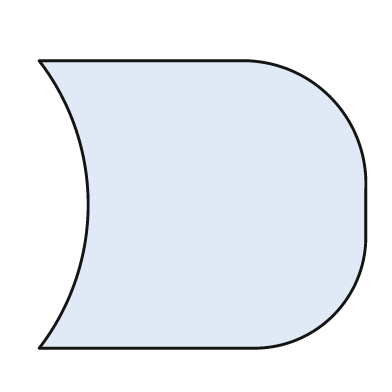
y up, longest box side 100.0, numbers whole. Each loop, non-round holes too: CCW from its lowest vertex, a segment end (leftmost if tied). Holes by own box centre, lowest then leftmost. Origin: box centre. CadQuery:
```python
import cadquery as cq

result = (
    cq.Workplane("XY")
    .moveTo(-50.0, -44.0)
    .lineTo(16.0, -44.0)
    .threePointArc((40.0, -34.0), (50.0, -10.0))
    .lineTo(50.0, 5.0)
    .threePointArc((39.0, 33.0), (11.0, 44.0))
    .lineTo(-50.0, 44.0)
    .threePointArc((-35.0, 0.0), (-50.0, -44.0))
    .close()
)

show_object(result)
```